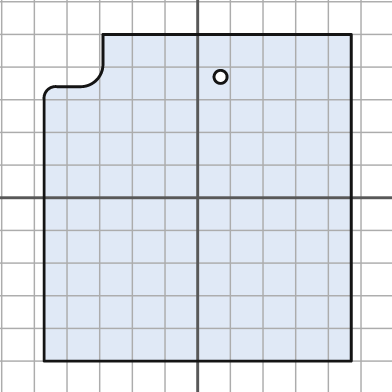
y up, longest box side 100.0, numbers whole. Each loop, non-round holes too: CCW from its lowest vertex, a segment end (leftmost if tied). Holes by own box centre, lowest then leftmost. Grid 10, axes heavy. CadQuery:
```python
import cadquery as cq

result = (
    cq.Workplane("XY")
    .moveTo(-47.0, -50.0)
    .lineTo(47.0, -50.0)
    .lineTo(47.0, 50.0)
    .lineTo(-29.0, 50.0)
    .lineTo(-29.0, 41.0)
    .threePointArc((-31.0, 36.0), (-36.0, 34.0))
    .lineTo(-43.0, 34.0)
    .threePointArc((-46.0, 33.0), (-47.0, 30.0))
    .close()
    .moveTo(7.0, 37.0)
    .circle(2.0)
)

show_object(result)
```